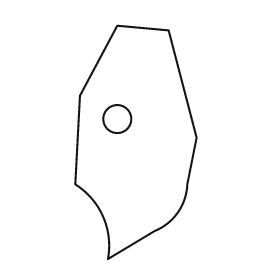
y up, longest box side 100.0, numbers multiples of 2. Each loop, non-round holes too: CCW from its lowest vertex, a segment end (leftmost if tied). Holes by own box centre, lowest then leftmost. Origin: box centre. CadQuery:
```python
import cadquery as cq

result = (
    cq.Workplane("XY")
    .moveTo(-12.0, -50.0)
    .lineTo(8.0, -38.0)
    .threePointArc((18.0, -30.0), (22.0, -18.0))
    .lineTo(26.0, 2.0)
    .lineTo(14.0, 48.0)
    .lineTo(-8.0, 50.0)
    .lineTo(-24.0, 20.0)
    .lineTo(-26.0, -18.0)
    .threePointArc((-14.0, -32.0), (-12.0, -50.0))
    .close()
    .moveTo(-8.0, 10.0)
    .circle(6.0)
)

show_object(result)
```